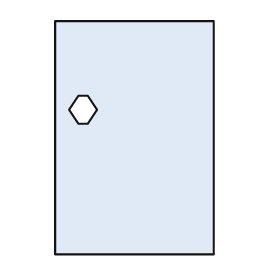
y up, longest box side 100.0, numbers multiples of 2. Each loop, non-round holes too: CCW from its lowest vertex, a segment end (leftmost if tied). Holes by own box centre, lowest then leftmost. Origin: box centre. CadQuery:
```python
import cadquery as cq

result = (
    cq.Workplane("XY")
    .moveTo(-34.0, -50.0)
    .lineTo(34.0, -50.0)
    .lineTo(34.0, 50.0)
    .lineTo(-34.0, 50.0)
    .close()
    .moveTo(-24.0, 6.0)
    .lineTo(-20.0, 6.0)
    .lineTo(-16.0, 12.0)
    .lineTo(-20.0, 18.0)
    .lineTo(-24.0, 18.0)
    .lineTo(-28.0, 12.0)
    .close()
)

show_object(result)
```